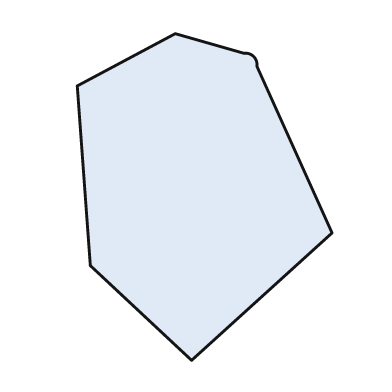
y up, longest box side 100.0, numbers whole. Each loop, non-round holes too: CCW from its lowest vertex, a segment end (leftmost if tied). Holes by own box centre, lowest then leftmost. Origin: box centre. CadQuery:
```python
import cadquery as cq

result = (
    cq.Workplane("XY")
    .moveTo(-4.0, -50.0)
    .lineTo(39.0, -11.0)
    .lineTo(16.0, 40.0)
    .threePointArc((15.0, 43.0), (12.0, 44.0))
    .lineTo(-9.0, 50.0)
    .lineTo(-39.0, 34.0)
    .lineTo(-35.0, -21.0)
    .close()
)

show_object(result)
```